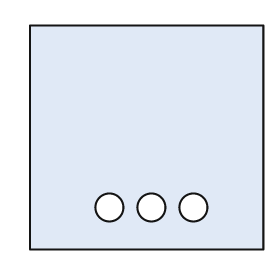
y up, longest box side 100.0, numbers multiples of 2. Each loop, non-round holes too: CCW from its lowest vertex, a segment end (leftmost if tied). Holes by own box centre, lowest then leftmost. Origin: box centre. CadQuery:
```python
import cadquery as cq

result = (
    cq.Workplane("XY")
    .moveTo(-50.0, -48.0)
    .lineTo(50.0, -48.0)
    .lineTo(50.0, 48.0)
    .lineTo(-50.0, 48.0)
    .close()
    .moveTo(-16.0, -30.0)
    .circle(6.0)
    .moveTo(2.0, -30.0)
    .circle(6.0)
    .moveTo(20.0, -30.0)
    .circle(6.0)
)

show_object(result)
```